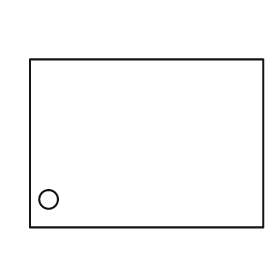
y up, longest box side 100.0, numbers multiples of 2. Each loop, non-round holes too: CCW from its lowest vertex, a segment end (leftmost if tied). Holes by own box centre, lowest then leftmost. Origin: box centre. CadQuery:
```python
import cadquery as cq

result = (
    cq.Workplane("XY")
    .moveTo(-50.0, -36.0)
    .lineTo(50.0, -36.0)
    .lineTo(50.0, 36.0)
    .lineTo(-50.0, 36.0)
    .close()
    .moveTo(-42.0, -24.0)
    .circle(4.0)
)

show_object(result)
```